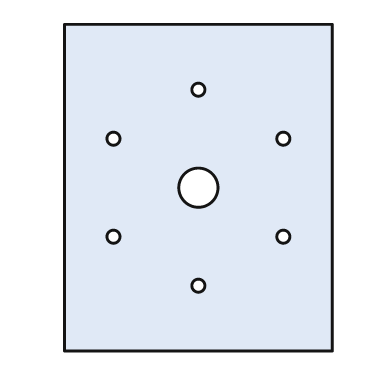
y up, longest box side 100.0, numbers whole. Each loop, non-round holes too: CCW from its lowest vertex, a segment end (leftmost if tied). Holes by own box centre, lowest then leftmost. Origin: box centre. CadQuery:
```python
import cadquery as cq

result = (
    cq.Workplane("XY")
    .moveTo(-41.0, -50.0)
    .lineTo(41.0, -50.0)
    .lineTo(41.0, 50.0)
    .lineTo(-41.0, 50.0)
    .close()
    .moveTo(0.0, -30.0)
    .circle(2.0)
    .moveTo(-26.0, -15.0)
    .circle(2.0)
    .moveTo(26.0, -15.0)
    .circle(2.0)
    .moveTo(0.0, 0.0)
    .circle(6.0)
    .moveTo(-26.0, 15.0)
    .circle(2.0)
    .moveTo(26.0, 15.0)
    .circle(2.0)
    .moveTo(0.0, 30.0)
    .circle(2.0)
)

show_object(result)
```